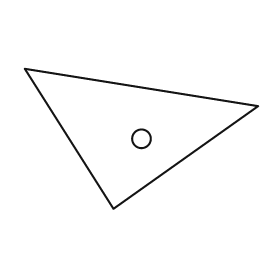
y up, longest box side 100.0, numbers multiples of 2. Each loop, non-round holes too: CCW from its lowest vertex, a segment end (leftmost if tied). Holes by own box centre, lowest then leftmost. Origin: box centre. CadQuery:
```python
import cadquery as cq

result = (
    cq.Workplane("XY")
    .moveTo(-12.0, -30.0)
    .lineTo(50.0, 14.0)
    .lineTo(-50.0, 30.0)
    .close()
    .moveTo(0.0, 0.0)
    .circle(4.0)
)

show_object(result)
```